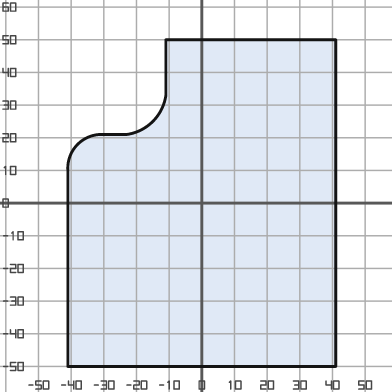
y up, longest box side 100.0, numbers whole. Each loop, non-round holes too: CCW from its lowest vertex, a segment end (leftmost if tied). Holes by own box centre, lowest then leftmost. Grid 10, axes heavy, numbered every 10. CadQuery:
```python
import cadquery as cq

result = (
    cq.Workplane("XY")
    .moveTo(-41.0, -50.0)
    .lineTo(41.0, -50.0)
    .lineTo(41.0, 50.0)
    .lineTo(-11.0, 50.0)
    .lineTo(-11.0, 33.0)
    .threePointArc((-15.0, 25.0), (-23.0, 21.0))
    .lineTo(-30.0, 21.0)
    .threePointArc((-38.0, 18.0), (-41.0, 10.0))
    .close()
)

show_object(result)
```